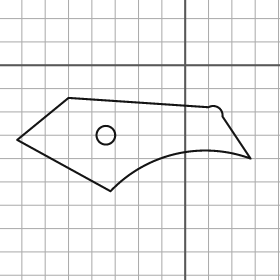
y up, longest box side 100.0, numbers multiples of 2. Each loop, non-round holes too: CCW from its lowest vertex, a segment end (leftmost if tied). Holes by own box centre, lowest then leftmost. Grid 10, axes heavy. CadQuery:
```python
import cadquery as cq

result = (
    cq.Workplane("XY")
    .moveTo(-32.0, -54.0)
    .threePointArc((-4.0, -38.0), (28.0, -40.0))
    .lineTo(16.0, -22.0)
    .threePointArc((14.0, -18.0), (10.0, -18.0))
    .lineTo(-50.0, -14.0)
    .lineTo(-72.0, -32.0)
    .close()
    .moveTo(-34.0, -30.0)
    .circle(4.0)
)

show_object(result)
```